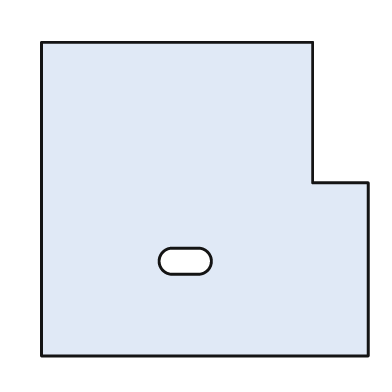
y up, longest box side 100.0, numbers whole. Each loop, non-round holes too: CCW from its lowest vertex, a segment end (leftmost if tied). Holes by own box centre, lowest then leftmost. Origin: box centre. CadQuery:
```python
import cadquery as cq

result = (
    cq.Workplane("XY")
    .moveTo(-50.0, -48.0)
    .lineTo(50.0, -48.0)
    .lineTo(50.0, 5.0)
    .lineTo(33.0, 5.0)
    .lineTo(33.0, 48.0)
    .lineTo(-50.0, 48.0)
    .close()
    .moveTo(-10.0, -23.0)
    .lineTo(-2.0, -23.0)
    .threePointArc((2.0, -19.0), (-2.0, -15.0))
    .lineTo(-10.0, -15.0)
    .threePointArc((-14.0, -19.0), (-10.0, -23.0))
    .close()
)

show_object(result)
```